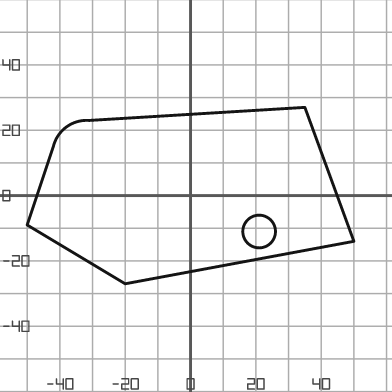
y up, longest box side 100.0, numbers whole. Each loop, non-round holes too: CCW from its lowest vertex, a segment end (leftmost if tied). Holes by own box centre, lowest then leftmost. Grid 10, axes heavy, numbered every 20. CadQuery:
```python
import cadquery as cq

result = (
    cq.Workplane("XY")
    .moveTo(-20.0, -27.0)
    .lineTo(50.0, -14.0)
    .lineTo(35.0, 27.0)
    .lineTo(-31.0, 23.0)
    .threePointArc((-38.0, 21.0), (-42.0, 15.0))
    .lineTo(-50.0, -9.0)
    .close()
    .moveTo(21.0, -11.0)
    .circle(5.0)
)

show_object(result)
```